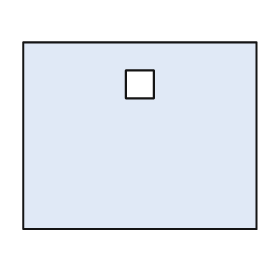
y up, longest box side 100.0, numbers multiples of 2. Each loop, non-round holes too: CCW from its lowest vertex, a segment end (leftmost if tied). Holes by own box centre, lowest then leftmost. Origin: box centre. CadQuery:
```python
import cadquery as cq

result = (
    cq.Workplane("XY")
    .moveTo(-50.0, -40.0)
    .lineTo(50.0, -40.0)
    .lineTo(50.0, 40.0)
    .lineTo(-50.0, 40.0)
    .close()
    .moveTo(-6.0, 16.0)
    .lineTo(6.0, 16.0)
    .lineTo(6.0, 28.0)
    .lineTo(-6.0, 28.0)
    .close()
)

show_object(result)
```